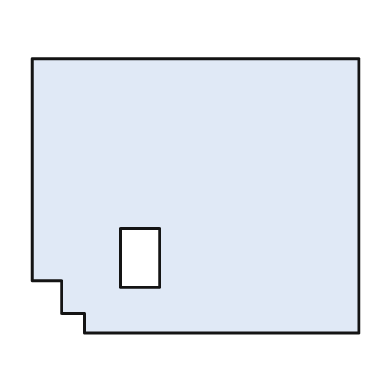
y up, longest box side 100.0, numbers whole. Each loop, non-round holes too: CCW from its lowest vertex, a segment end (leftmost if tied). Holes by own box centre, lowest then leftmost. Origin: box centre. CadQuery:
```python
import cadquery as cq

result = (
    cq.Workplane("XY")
    .moveTo(-34.0, -42.0)
    .lineTo(50.0, -42.0)
    .lineTo(50.0, 42.0)
    .lineTo(-50.0, 42.0)
    .lineTo(-50.0, -26.0)
    .lineTo(-41.0, -26.0)
    .lineTo(-41.0, -36.0)
    .lineTo(-34.0, -36.0)
    .close()
    .moveTo(-23.0, -28.0)
    .lineTo(-11.0, -28.0)
    .lineTo(-11.0, -10.0)
    .lineTo(-23.0, -10.0)
    .close()
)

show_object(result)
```